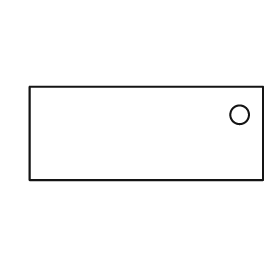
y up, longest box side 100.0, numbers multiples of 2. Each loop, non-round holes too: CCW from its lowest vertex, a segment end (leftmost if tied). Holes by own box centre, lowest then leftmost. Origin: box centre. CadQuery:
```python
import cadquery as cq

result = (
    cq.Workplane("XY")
    .moveTo(-50.0, -20.0)
    .lineTo(50.0, -20.0)
    .lineTo(50.0, 20.0)
    .lineTo(-50.0, 20.0)
    .close()
    .moveTo(40.0, 8.0)
    .circle(4.0)
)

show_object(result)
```